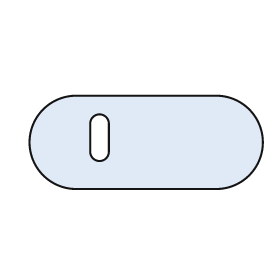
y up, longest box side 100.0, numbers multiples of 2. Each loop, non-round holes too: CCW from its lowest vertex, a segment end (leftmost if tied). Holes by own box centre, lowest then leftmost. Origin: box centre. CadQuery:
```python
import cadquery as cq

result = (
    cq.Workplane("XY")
    .moveTo(-30.0, -20.0)
    .lineTo(30.0, -20.0)
    .threePointArc((50.0, 0.0), (30.0, 20.0))
    .lineTo(-30.0, 20.0)
    .threePointArc((-50.0, 0.0), (-30.0, -20.0))
    .close()
    .moveTo(-24.0, -4.0)
    .threePointArc((-20.0, -8.0), (-16.0, -4.0))
    .lineTo(-16.0, 8.0)
    .threePointArc((-20.0, 12.0), (-24.0, 8.0))
    .close()
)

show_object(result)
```